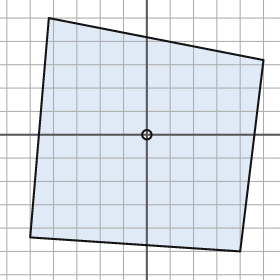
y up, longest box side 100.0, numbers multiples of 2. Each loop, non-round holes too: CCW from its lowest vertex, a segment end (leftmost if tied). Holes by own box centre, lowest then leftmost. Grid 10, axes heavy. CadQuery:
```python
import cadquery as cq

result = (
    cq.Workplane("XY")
    .moveTo(40.0, -50.0)
    .lineTo(50.0, 32.0)
    .lineTo(-42.0, 50.0)
    .lineTo(-50.0, -44.0)
    .close()
    .moveTo(0.0, 0.0)
    .circle(2.0)
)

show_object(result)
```